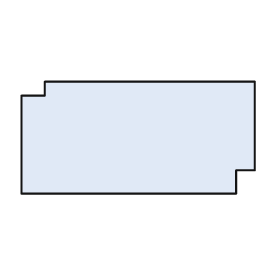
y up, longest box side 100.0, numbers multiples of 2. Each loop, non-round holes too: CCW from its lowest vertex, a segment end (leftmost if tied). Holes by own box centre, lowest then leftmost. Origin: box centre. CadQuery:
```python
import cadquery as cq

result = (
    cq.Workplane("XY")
    .moveTo(-50.0, -24.0)
    .lineTo(42.0, -24.0)
    .lineTo(42.0, -14.0)
    .lineTo(50.0, -14.0)
    .lineTo(50.0, 24.0)
    .lineTo(-40.0, 24.0)
    .lineTo(-40.0, 18.0)
    .lineTo(-50.0, 18.0)
    .close()
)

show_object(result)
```